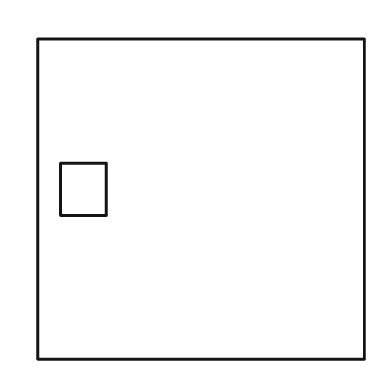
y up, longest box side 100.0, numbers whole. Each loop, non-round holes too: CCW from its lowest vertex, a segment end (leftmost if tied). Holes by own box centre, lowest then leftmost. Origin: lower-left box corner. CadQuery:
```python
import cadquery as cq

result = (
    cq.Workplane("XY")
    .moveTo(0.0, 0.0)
    .lineTo(100.0, 0.0)
    .lineTo(100.0, 98.0)
    .lineTo(0.0, 98.0)
    .close()
    .moveTo(7.0, 44.0)
    .lineTo(21.0, 44.0)
    .lineTo(21.0, 60.0)
    .lineTo(7.0, 60.0)
    .close()
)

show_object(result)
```